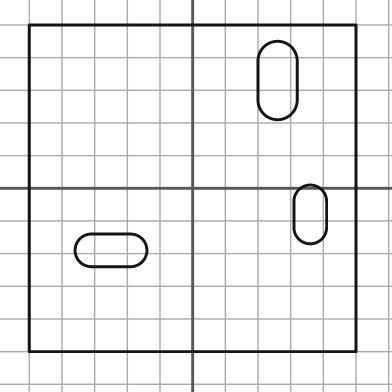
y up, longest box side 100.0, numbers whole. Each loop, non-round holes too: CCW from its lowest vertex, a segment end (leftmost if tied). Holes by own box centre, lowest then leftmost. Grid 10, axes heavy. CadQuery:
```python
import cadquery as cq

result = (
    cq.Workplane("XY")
    .moveTo(-50.0, -50.0)
    .lineTo(50.0, -50.0)
    .lineTo(50.0, 50.0)
    .lineTo(-50.0, 50.0)
    .close()
    .moveTo(-31.0, -24.0)
    .lineTo(-19.0, -24.0)
    .threePointArc((-14.0, -19.0), (-19.0, -14.0))
    .lineTo(-31.0, -14.0)
    .threePointArc((-36.0, -19.0), (-31.0, -24.0))
    .close()
    .moveTo(31.0, -12.0)
    .threePointArc((36.0, -17.0), (41.0, -12.0))
    .lineTo(41.0, -4.0)
    .threePointArc((36.0, 1.0), (31.0, -4.0))
    .close()
    .moveTo(20.0, 27.0)
    .threePointArc((26.0, 21.0), (32.0, 27.0))
    .lineTo(32.0, 39.0)
    .threePointArc((26.0, 45.0), (20.0, 39.0))
    .close()
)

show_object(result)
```